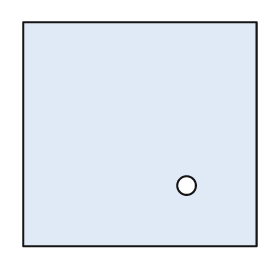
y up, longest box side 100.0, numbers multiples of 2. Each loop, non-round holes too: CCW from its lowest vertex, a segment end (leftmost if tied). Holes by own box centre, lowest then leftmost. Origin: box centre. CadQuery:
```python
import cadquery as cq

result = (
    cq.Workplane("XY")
    .moveTo(-50.0, -48.0)
    .lineTo(50.0, -48.0)
    .lineTo(50.0, 48.0)
    .lineTo(-50.0, 48.0)
    .close()
    .moveTo(20.0, -22.0)
    .circle(4.0)
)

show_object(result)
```